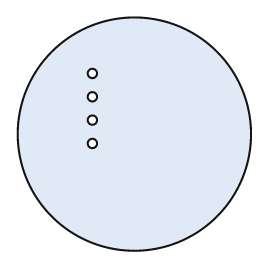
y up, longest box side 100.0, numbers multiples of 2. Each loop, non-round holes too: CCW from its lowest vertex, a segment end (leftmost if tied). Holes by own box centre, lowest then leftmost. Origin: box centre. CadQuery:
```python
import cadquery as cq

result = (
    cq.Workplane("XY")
    .moveTo(0.0, 0.0)
    .circle(50.0)
    .moveTo(-18.0, -4.0)
    .circle(2.0)
    .moveTo(-18.0, 6.0)
    .circle(2.0)
    .moveTo(-18.0, 16.0)
    .circle(2.0)
    .moveTo(-18.0, 26.0)
    .circle(2.0)
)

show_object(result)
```